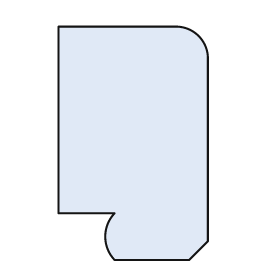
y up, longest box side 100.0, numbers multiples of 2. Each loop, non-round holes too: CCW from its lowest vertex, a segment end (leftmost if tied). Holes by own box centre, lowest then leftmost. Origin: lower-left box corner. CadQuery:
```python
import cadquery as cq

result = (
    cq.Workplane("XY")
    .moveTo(24.0, 0.0)
    .lineTo(56.0, 0.0)
    .lineTo(64.0, 8.0)
    .lineTo(64.0, 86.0)
    .threePointArc((60.0, 96.0), (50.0, 100.0))
    .lineTo(0.0, 100.0)
    .lineTo(0.0, 20.0)
    .lineTo(24.0, 20.0)
    .threePointArc((20.0, 10.0), (24.0, 0.0))
    .close()
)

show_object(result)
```